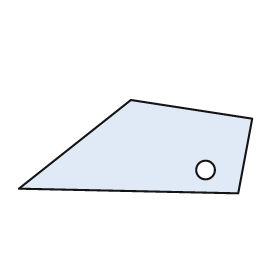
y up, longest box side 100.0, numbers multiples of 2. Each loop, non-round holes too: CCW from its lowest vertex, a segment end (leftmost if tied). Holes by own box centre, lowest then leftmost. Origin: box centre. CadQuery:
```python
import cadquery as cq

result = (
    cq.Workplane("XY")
    .moveTo(44.0, -20.0)
    .lineTo(50.0, 12.0)
    .lineTo(-2.0, 20.0)
    .lineTo(-50.0, -18.0)
    .close()
    .moveTo(30.0, -10.0)
    .circle(4.0)
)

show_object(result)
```